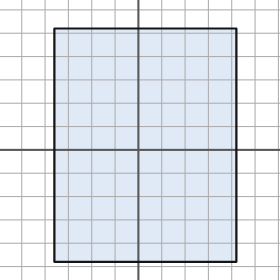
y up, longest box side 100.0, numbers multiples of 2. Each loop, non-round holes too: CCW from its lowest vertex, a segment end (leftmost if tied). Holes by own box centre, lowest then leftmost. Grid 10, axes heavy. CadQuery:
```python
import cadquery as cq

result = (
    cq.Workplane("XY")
    .moveTo(-36.0, -48.0)
    .lineTo(42.0, -48.0)
    .lineTo(42.0, 52.0)
    .lineTo(-36.0, 52.0)
    .close()
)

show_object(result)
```